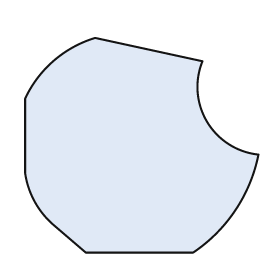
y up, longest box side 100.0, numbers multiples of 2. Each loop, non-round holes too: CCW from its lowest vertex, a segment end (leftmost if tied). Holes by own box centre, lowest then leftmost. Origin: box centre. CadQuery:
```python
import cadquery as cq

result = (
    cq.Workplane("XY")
    .moveTo(-24.0, -46.0)
    .lineTo(22.0, -46.0)
    .threePointArc((40.0, -28.0), (50.0, -4.0))
    .threePointArc((28.0, 10.0), (26.0, 36.0))
    .lineTo(-20.0, 46.0)
    .threePointArc((-38.0, 36.0), (-50.0, 20.0))
    .lineTo(-50.0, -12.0)
    .threePointArc((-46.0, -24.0), (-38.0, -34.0))
    .close()
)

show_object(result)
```